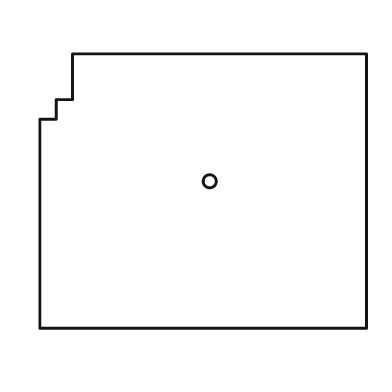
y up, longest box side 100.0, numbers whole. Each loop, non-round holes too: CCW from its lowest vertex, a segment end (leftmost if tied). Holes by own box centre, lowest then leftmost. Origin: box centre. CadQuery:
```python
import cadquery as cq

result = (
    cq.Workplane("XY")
    .moveTo(-50.0, -42.0)
    .lineTo(50.0, -42.0)
    .lineTo(50.0, 42.0)
    .lineTo(-40.0, 42.0)
    .lineTo(-40.0, 28.0)
    .lineTo(-45.0, 28.0)
    .lineTo(-45.0, 22.0)
    .lineTo(-50.0, 22.0)
    .close()
    .moveTo(2.0, 3.0)
    .circle(2.0)
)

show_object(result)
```